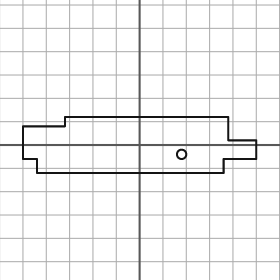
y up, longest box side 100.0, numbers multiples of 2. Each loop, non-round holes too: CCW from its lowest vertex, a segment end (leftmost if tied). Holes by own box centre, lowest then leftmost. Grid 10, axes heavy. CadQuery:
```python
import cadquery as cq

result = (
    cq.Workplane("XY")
    .moveTo(-44.0, -12.0)
    .lineTo(36.0, -12.0)
    .lineTo(36.0, -6.0)
    .lineTo(50.0, -6.0)
    .lineTo(50.0, 2.0)
    .lineTo(38.0, 2.0)
    .lineTo(38.0, 12.0)
    .lineTo(-32.0, 12.0)
    .lineTo(-32.0, 8.0)
    .lineTo(-50.0, 8.0)
    .lineTo(-50.0, -6.0)
    .lineTo(-44.0, -6.0)
    .close()
    .moveTo(18.0, -4.0)
    .circle(2.0)
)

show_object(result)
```